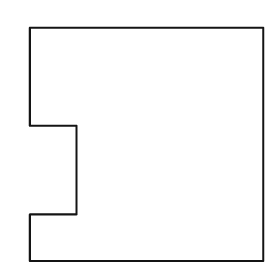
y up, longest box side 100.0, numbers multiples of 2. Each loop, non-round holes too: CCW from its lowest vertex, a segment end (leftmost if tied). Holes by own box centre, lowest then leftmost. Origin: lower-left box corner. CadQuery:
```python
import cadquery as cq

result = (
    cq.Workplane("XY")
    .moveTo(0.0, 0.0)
    .lineTo(100.0, 0.0)
    .lineTo(100.0, 100.0)
    .lineTo(0.0, 100.0)
    .lineTo(0.0, 58.0)
    .lineTo(20.0, 58.0)
    .lineTo(20.0, 20.0)
    .lineTo(0.0, 20.0)
    .close()
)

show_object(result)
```